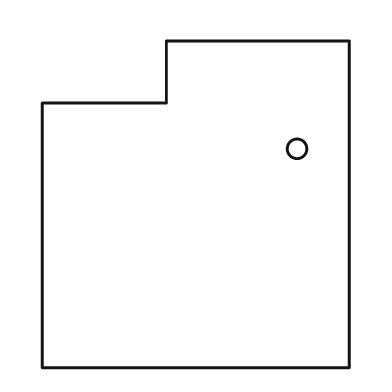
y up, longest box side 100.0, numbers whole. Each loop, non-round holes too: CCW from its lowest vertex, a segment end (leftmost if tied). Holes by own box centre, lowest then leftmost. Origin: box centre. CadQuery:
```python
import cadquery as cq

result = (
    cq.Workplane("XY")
    .moveTo(-47.0, -50.0)
    .lineTo(47.0, -50.0)
    .lineTo(47.0, 50.0)
    .lineTo(-9.0, 50.0)
    .lineTo(-9.0, 31.0)
    .lineTo(-47.0, 31.0)
    .close()
    .moveTo(31.0, 17.0)
    .circle(3.0)
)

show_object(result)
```